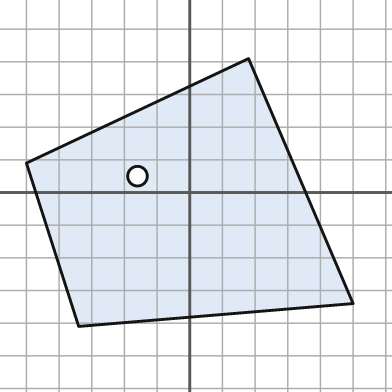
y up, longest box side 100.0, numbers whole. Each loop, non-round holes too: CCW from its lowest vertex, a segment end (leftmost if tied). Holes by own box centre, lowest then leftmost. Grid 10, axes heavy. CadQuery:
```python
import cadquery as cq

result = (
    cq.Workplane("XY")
    .moveTo(-34.0, -41.0)
    .lineTo(50.0, -34.0)
    .lineTo(18.0, 41.0)
    .lineTo(-50.0, 9.0)
    .close()
    .moveTo(-16.0, 5.0)
    .circle(3.0)
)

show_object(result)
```